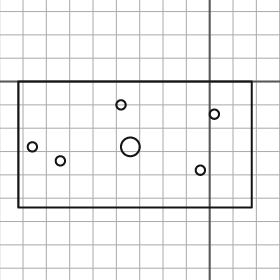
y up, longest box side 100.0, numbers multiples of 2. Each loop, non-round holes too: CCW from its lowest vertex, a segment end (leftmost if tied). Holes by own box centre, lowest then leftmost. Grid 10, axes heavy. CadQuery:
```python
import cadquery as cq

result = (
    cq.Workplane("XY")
    .moveTo(-82.0, -54.0)
    .lineTo(18.0, -54.0)
    .lineTo(18.0, 0.0)
    .lineTo(-82.0, 0.0)
    .close()
    .moveTo(-4.0, -38.0)
    .circle(2.0)
    .moveTo(-64.0, -34.0)
    .circle(2.0)
    .moveTo(-76.0, -28.0)
    .circle(2.0)
    .moveTo(-34.0, -28.0)
    .circle(4.0)
    .moveTo(2.0, -14.0)
    .circle(2.0)
    .moveTo(-38.0, -10.0)
    .circle(2.0)
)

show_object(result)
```